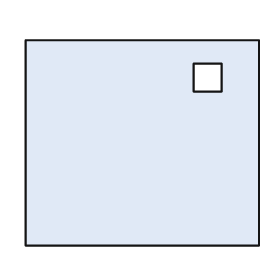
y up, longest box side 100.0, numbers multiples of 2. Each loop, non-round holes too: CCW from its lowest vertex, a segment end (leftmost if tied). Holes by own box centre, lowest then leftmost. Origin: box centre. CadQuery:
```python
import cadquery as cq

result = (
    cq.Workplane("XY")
    .moveTo(-50.0, -44.0)
    .lineTo(50.0, -44.0)
    .lineTo(50.0, 44.0)
    .lineTo(-50.0, 44.0)
    .close()
    .moveTo(22.0, 22.0)
    .lineTo(34.0, 22.0)
    .lineTo(34.0, 34.0)
    .lineTo(22.0, 34.0)
    .close()
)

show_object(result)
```